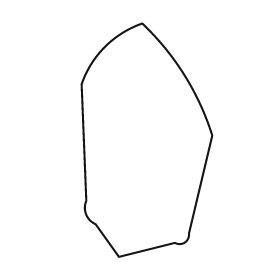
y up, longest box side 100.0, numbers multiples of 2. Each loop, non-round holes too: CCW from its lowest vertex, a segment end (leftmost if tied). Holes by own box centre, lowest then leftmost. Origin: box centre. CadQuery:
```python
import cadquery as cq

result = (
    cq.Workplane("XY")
    .moveTo(-12.0, -50.0)
    .lineTo(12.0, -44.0)
    .threePointArc((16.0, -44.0), (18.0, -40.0))
    .lineTo(28.0, 2.0)
    .threePointArc((16.0, 28.0), (-2.0, 50.0))
    .threePointArc((-18.0, 40.0), (-28.0, 24.0))
    .lineTo(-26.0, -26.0)
    .threePointArc((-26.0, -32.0), (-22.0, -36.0))
    .close()
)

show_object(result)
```